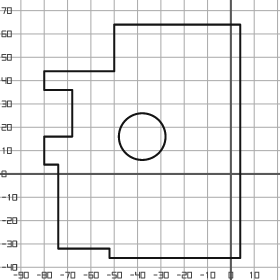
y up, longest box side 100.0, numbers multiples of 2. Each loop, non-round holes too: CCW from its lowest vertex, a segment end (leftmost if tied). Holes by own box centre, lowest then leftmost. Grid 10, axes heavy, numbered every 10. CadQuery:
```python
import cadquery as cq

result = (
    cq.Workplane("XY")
    .moveTo(-52.0, -36.0)
    .lineTo(4.0, -36.0)
    .lineTo(4.0, 64.0)
    .lineTo(-50.0, 64.0)
    .lineTo(-50.0, 44.0)
    .lineTo(-80.0, 44.0)
    .lineTo(-80.0, 36.0)
    .lineTo(-68.0, 36.0)
    .lineTo(-68.0, 16.0)
    .lineTo(-80.0, 16.0)
    .lineTo(-80.0, 4.0)
    .lineTo(-74.0, 4.0)
    .lineTo(-74.0, -32.0)
    .lineTo(-52.0, -32.0)
    .close()
    .moveTo(-38.0, 16.0)
    .circle(10.0)
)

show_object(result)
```